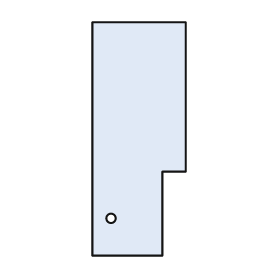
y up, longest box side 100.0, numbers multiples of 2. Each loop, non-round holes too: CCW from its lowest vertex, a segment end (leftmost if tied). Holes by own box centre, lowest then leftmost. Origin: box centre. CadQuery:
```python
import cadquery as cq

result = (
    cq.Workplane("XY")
    .moveTo(-20.0, -50.0)
    .lineTo(10.0, -50.0)
    .lineTo(10.0, -14.0)
    .lineTo(20.0, -14.0)
    .lineTo(20.0, 50.0)
    .lineTo(-20.0, 50.0)
    .close()
    .moveTo(-12.0, -34.0)
    .circle(2.0)
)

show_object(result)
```